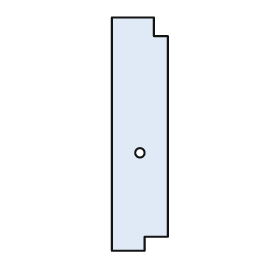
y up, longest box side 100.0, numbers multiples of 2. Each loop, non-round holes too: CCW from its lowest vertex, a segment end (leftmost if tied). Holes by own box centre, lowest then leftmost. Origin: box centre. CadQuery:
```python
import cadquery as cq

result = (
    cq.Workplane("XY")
    .moveTo(-12.0, -50.0)
    .lineTo(2.0, -50.0)
    .lineTo(2.0, -44.0)
    .lineTo(12.0, -44.0)
    .lineTo(12.0, 42.0)
    .lineTo(6.0, 42.0)
    .lineTo(6.0, 50.0)
    .lineTo(-12.0, 50.0)
    .close()
    .moveTo(0.0, -8.0)
    .circle(2.0)
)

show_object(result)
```